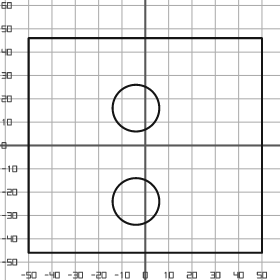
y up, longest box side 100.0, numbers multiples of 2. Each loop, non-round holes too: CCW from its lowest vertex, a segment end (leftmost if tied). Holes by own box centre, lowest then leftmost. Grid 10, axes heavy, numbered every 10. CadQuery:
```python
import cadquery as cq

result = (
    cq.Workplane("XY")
    .moveTo(-50.0, -46.0)
    .lineTo(50.0, -46.0)
    .lineTo(50.0, 46.0)
    .lineTo(-50.0, 46.0)
    .close()
    .moveTo(-4.0, -24.0)
    .circle(10.0)
    .moveTo(-4.0, 16.0)
    .circle(10.0)
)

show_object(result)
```